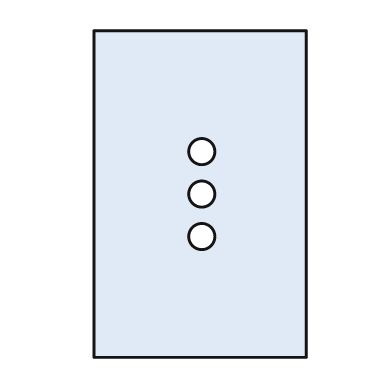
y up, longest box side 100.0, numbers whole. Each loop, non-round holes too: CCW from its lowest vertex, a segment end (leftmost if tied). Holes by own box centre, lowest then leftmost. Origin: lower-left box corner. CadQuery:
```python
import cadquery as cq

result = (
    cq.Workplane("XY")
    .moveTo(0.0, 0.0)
    .lineTo(65.0, 0.0)
    .lineTo(65.0, 100.0)
    .lineTo(0.0, 100.0)
    .close()
    .moveTo(33.0, 37.0)
    .circle(4.0)
    .moveTo(33.0, 50.0)
    .circle(4.0)
    .moveTo(33.0, 63.0)
    .circle(4.0)
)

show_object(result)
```